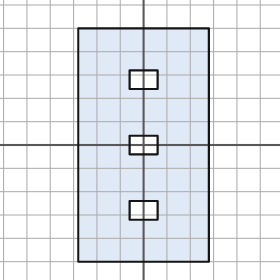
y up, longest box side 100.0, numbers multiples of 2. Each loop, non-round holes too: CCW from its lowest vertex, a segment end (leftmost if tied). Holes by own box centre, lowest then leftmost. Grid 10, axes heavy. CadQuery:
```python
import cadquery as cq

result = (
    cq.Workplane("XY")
    .moveTo(-28.0, -50.0)
    .lineTo(28.0, -50.0)
    .lineTo(28.0, 50.0)
    .lineTo(-28.0, 50.0)
    .close()
    .moveTo(-6.0, -32.0)
    .lineTo(6.0, -32.0)
    .lineTo(6.0, -24.0)
    .lineTo(-6.0, -24.0)
    .close()
    .moveTo(-6.0, -4.0)
    .lineTo(6.0, -4.0)
    .lineTo(6.0, 4.0)
    .lineTo(-6.0, 4.0)
    .close()
    .moveTo(-6.0, 24.0)
    .lineTo(6.0, 24.0)
    .lineTo(6.0, 32.0)
    .lineTo(-6.0, 32.0)
    .close()
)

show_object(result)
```